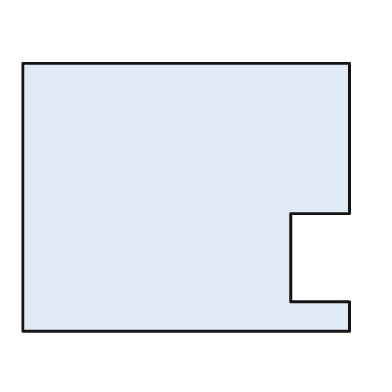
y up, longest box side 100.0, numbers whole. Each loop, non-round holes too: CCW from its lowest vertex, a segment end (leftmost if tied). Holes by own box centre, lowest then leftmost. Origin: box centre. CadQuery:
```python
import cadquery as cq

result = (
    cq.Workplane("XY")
    .moveTo(-50.0, -41.0)
    .lineTo(50.0, -41.0)
    .lineTo(50.0, -32.0)
    .lineTo(32.0, -32.0)
    .lineTo(32.0, -5.0)
    .lineTo(50.0, -5.0)
    .lineTo(50.0, 41.0)
    .lineTo(-50.0, 41.0)
    .close()
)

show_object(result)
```